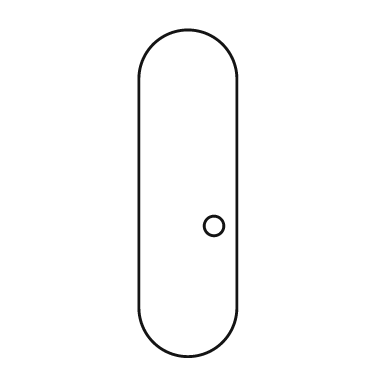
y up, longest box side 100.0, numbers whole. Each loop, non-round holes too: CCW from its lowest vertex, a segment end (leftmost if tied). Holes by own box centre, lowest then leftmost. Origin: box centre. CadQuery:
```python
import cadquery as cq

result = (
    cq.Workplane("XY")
    .moveTo(-15.0, -35.0)
    .threePointArc((0.0, -50.0), (15.0, -35.0))
    .lineTo(15.0, 35.0)
    .threePointArc((0.0, 50.0), (-15.0, 35.0))
    .close()
    .moveTo(8.0, -10.0)
    .circle(3.0)
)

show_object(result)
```